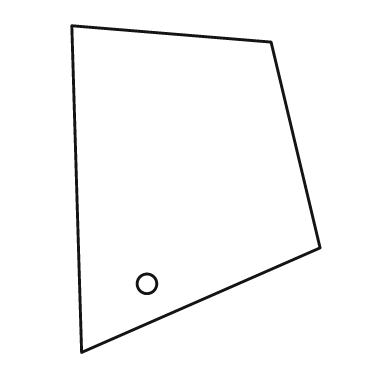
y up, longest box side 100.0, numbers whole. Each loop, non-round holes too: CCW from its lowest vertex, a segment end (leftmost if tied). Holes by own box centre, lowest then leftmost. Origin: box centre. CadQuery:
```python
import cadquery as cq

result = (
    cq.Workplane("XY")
    .moveTo(-35.0, -50.0)
    .lineTo(38.0, -18.0)
    .lineTo(23.0, 45.0)
    .lineTo(-38.0, 50.0)
    .close()
    .moveTo(-15.0, -29.0)
    .circle(3.0)
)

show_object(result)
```